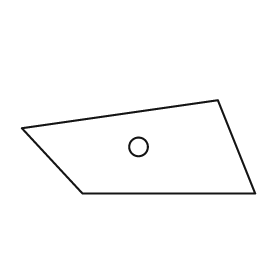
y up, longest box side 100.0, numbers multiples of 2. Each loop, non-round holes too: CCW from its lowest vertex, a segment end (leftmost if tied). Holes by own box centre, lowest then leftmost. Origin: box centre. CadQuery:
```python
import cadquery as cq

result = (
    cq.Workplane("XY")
    .moveTo(-24.0, -20.0)
    .lineTo(50.0, -20.0)
    .lineTo(34.0, 20.0)
    .lineTo(-50.0, 8.0)
    .close()
    .moveTo(0.0, 0.0)
    .circle(4.0)
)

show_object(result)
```